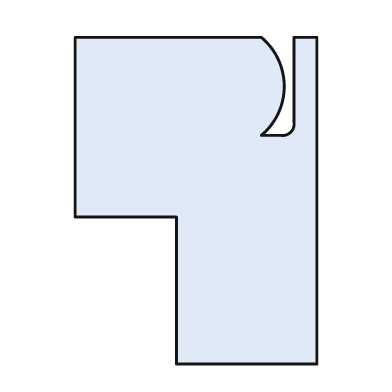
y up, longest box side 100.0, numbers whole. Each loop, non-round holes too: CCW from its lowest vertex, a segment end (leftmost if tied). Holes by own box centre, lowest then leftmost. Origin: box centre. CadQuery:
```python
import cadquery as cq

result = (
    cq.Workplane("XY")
    .moveTo(-6.0, -50.0)
    .lineTo(37.0, -50.0)
    .lineTo(37.0, 50.0)
    .lineTo(30.0, 50.0)
    .lineTo(30.0, 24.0)
    .threePointArc((29.0, 21.0), (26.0, 20.0))
    .lineTo(20.0, 20.0)
    .threePointArc((27.0, 35.0), (20.0, 50.0))
    .lineTo(-37.0, 50.0)
    .lineTo(-37.0, -5.0)
    .lineTo(-6.0, -5.0)
    .close()
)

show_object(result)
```